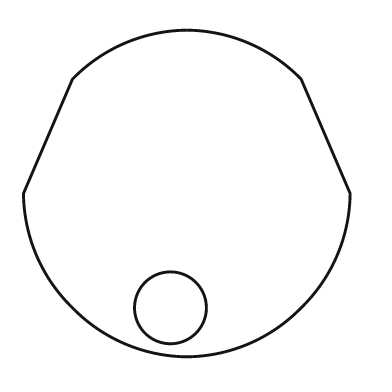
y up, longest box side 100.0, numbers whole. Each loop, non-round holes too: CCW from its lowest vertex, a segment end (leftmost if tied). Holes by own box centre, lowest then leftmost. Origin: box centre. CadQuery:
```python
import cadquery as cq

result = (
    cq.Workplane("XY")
    .moveTo(0.0, -50.0)
    .threePointArc((19.0, -46.0), (35.0, -35.0))
    .threePointArc((46.0, -19.0), (50.0, 0.0))
    .lineTo(35.0, 35.0)
    .threePointArc((19.0, 46.0), (0.0, 50.0))
    .threePointArc((-19.0, 46.0), (-35.0, 35.0))
    .lineTo(-50.0, 0.0)
    .threePointArc((-46.0, -19.0), (-35.0, -35.0))
    .threePointArc((-19.0, -46.0), (0.0, -50.0))
    .close()
    .moveTo(-5.0, -35.0)
    .circle(11.0)
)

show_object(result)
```